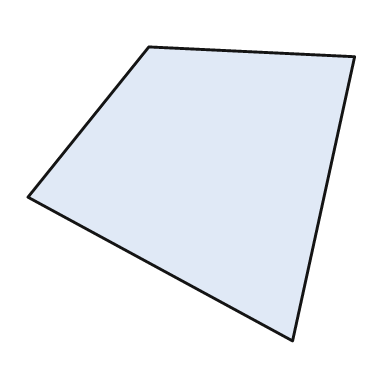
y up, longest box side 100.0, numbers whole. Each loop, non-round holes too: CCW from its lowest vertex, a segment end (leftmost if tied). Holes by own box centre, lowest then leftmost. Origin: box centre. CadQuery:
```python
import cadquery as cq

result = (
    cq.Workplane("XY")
    .moveTo(31.0, -45.0)
    .lineTo(50.0, 42.0)
    .lineTo(-13.0, 45.0)
    .lineTo(-50.0, -1.0)
    .close()
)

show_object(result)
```